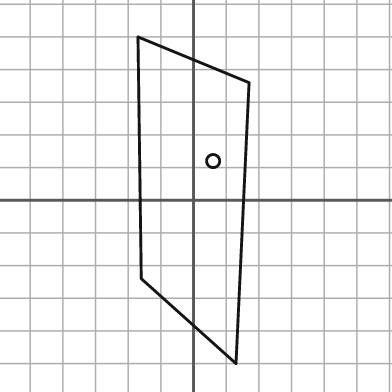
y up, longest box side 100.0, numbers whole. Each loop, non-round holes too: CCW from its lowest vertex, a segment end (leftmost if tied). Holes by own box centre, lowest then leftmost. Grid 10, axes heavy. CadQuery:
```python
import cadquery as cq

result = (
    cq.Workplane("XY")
    .moveTo(13.0, -50.0)
    .lineTo(17.0, 36.0)
    .lineTo(-17.0, 50.0)
    .lineTo(-16.0, -24.0)
    .close()
    .moveTo(6.0, 12.0)
    .circle(2.0)
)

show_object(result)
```